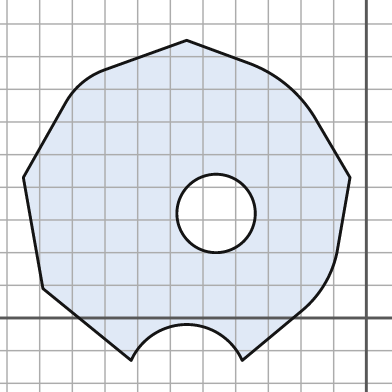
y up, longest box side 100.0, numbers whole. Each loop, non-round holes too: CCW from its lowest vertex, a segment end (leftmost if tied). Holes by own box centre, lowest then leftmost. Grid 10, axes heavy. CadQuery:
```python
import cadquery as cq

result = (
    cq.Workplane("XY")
    .moveTo(-72.0, -13.0)
    .threePointArc((-55.0, -2.0), (-38.0, -13.0))
    .lineTo(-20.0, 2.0)
    .threePointArc((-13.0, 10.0), (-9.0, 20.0))
    .lineTo(-5.0, 43.0)
    .lineTo(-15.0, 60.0)
    .threePointArc((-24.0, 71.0), (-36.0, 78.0))
    .lineTo(-55.0, 85.0)
    .lineTo(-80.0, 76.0)
    .threePointArc((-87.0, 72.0), (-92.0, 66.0))
    .lineTo(-105.0, 43.0)
    .lineTo(-99.0, 9.0)
    .close()
    .moveTo(-46.0, 32.0)
    .circle(12.0)
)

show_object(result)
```